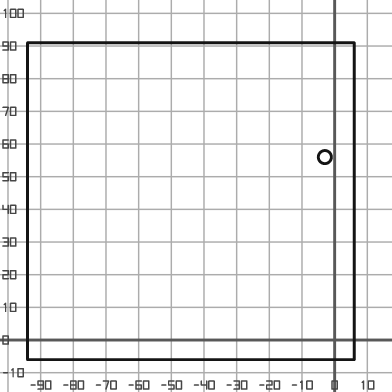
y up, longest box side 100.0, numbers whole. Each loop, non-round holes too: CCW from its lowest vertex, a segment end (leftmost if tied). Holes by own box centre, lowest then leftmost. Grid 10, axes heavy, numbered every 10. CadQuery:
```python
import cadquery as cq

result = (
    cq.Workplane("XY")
    .moveTo(-94.0, -6.0)
    .lineTo(6.0, -6.0)
    .lineTo(6.0, 91.0)
    .lineTo(-94.0, 91.0)
    .close()
    .moveTo(-3.0, 56.0)
    .circle(2.0)
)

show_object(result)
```